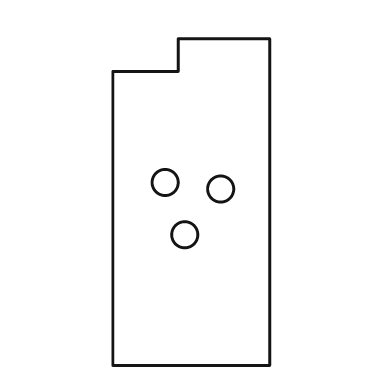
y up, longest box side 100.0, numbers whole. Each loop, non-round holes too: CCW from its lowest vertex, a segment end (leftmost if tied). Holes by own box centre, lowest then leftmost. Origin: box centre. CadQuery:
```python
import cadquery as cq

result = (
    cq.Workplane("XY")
    .moveTo(-24.0, -50.0)
    .lineTo(24.0, -50.0)
    .lineTo(24.0, 50.0)
    .lineTo(-4.0, 50.0)
    .lineTo(-4.0, 40.0)
    .lineTo(-24.0, 40.0)
    .close()
    .moveTo(-2.0, -10.0)
    .circle(4.0)
    .moveTo(9.0, 4.0)
    .circle(4.0)
    .moveTo(-8.0, 6.0)
    .circle(4.0)
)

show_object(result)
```